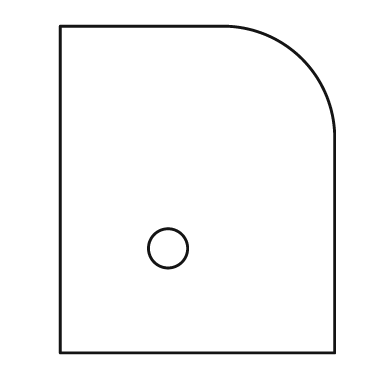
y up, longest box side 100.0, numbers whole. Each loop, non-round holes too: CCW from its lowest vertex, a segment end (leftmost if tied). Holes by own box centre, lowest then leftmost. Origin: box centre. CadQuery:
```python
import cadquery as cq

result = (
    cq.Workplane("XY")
    .moveTo(-42.0, -50.0)
    .lineTo(42.0, -50.0)
    .lineTo(42.0, 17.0)
    .threePointArc((32.0, 40.0), (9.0, 50.0))
    .lineTo(-42.0, 50.0)
    .close()
    .moveTo(-9.0, -18.0)
    .circle(6.0)
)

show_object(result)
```